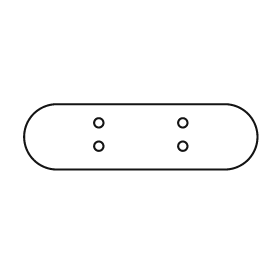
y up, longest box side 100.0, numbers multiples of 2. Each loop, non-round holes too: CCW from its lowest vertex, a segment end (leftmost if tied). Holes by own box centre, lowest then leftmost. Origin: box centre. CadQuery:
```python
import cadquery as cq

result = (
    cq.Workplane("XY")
    .moveTo(-36.0, -14.0)
    .lineTo(36.0, -14.0)
    .threePointArc((50.0, 0.0), (36.0, 14.0))
    .lineTo(-36.0, 14.0)
    .threePointArc((-50.0, 0.0), (-36.0, -14.0))
    .close()
    .moveTo(-18.0, -4.0)
    .circle(2.0)
    .moveTo(18.0, -4.0)
    .circle(2.0)
    .moveTo(-18.0, 6.0)
    .circle(2.0)
    .moveTo(18.0, 6.0)
    .circle(2.0)
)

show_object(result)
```